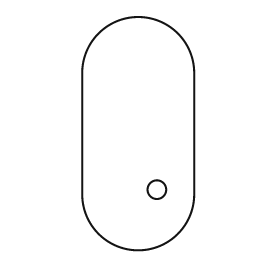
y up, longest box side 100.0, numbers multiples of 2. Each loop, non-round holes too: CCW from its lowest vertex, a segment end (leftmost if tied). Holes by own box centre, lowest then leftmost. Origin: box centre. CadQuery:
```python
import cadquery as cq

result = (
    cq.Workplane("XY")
    .moveTo(-24.0, -26.0)
    .threePointArc((0.0, -50.0), (24.0, -26.0))
    .lineTo(24.0, 26.0)
    .threePointArc((0.0, 50.0), (-24.0, 26.0))
    .close()
    .moveTo(8.0, -24.0)
    .circle(4.0)
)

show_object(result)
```